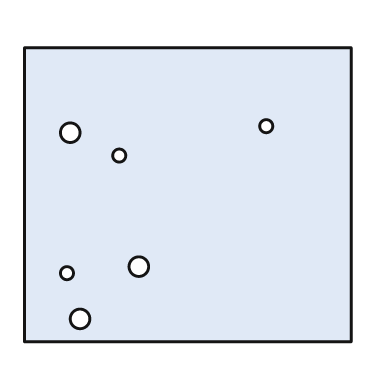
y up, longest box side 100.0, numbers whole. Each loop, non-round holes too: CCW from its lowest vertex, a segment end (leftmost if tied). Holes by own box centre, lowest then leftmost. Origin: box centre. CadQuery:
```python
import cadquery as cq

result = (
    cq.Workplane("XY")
    .moveTo(-50.0, -45.0)
    .lineTo(50.0, -45.0)
    .lineTo(50.0, 45.0)
    .lineTo(-50.0, 45.0)
    .close()
    .moveTo(-33.0, -38.0)
    .circle(3.0)
    .moveTo(-37.0, -24.0)
    .circle(2.0)
    .moveTo(-15.0, -22.0)
    .circle(3.0)
    .moveTo(-21.0, 12.0)
    .circle(2.0)
    .moveTo(-36.0, 19.0)
    .circle(3.0)
    .moveTo(24.0, 21.0)
    .circle(2.0)
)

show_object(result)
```